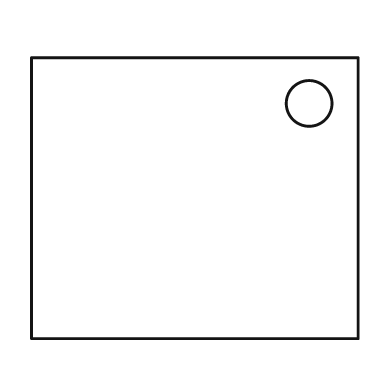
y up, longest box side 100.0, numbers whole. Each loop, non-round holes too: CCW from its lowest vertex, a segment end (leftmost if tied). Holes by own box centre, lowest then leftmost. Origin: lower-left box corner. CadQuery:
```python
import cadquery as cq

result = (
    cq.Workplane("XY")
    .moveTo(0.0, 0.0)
    .lineTo(100.0, 0.0)
    .lineTo(100.0, 86.0)
    .lineTo(0.0, 86.0)
    .close()
    .moveTo(85.0, 72.0)
    .circle(7.0)
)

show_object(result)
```